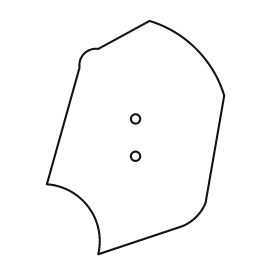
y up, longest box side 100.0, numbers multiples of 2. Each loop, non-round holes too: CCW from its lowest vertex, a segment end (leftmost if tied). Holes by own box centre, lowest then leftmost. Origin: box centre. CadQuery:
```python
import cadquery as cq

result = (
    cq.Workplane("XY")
    .moveTo(-16.0, -50.0)
    .lineTo(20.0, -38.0)
    .threePointArc((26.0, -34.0), (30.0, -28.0))
    .lineTo(38.0, 18.0)
    .threePointArc((26.0, 38.0), (6.0, 50.0))
    .lineTo(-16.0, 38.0)
    .threePointArc((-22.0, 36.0), (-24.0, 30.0))
    .lineTo(-38.0, -20.0)
    .threePointArc((-20.0, -30.0), (-16.0, -50.0))
    .close()
    .moveTo(0.0, -8.0)
    .circle(2.0)
    .moveTo(0.0, 8.0)
    .circle(2.0)
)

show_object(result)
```